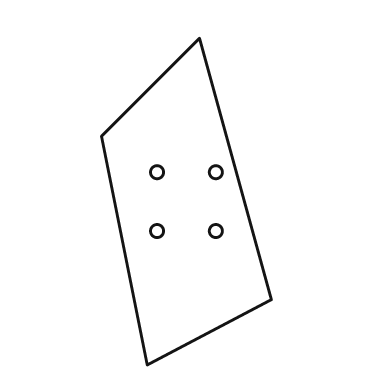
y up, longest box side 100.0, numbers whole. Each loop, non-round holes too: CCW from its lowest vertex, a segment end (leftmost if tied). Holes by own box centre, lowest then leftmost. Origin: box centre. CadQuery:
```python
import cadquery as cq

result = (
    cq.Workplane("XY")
    .moveTo(-12.0, -50.0)
    .lineTo(26.0, -30.0)
    .lineTo(4.0, 50.0)
    .lineTo(-26.0, 20.0)
    .close()
    .moveTo(-9.0, -9.0)
    .circle(2.0)
    .moveTo(9.0, -9.0)
    .circle(2.0)
    .moveTo(-9.0, 9.0)
    .circle(2.0)
    .moveTo(9.0, 9.0)
    .circle(2.0)
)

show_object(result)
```